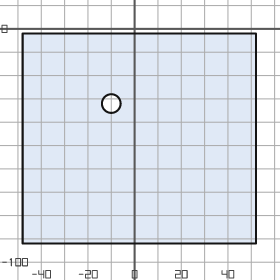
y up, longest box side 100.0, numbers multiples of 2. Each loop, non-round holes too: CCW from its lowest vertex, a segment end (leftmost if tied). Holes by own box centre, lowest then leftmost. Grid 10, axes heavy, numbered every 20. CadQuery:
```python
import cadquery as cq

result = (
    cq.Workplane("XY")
    .moveTo(-48.0, -92.0)
    .lineTo(52.0, -92.0)
    .lineTo(52.0, -2.0)
    .lineTo(-48.0, -2.0)
    .close()
    .moveTo(-10.0, -32.0)
    .circle(4.0)
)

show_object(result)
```